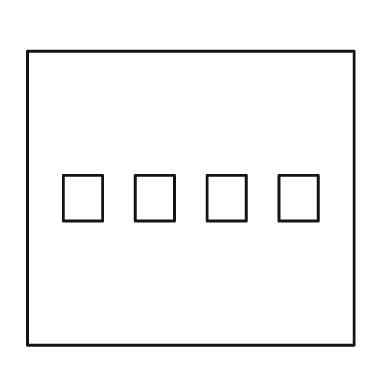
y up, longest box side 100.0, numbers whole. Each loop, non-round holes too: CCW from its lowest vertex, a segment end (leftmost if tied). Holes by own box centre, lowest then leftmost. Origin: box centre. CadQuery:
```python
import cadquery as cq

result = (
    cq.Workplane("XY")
    .moveTo(-50.0, -45.0)
    .lineTo(50.0, -45.0)
    .lineTo(50.0, 45.0)
    .lineTo(-50.0, 45.0)
    .close()
    .moveTo(-39.0, -7.0)
    .lineTo(-27.0, -7.0)
    .lineTo(-27.0, 7.0)
    .lineTo(-39.0, 7.0)
    .close()
    .moveTo(-17.0, -7.0)
    .lineTo(-5.0, -7.0)
    .lineTo(-5.0, 7.0)
    .lineTo(-17.0, 7.0)
    .close()
    .moveTo(5.0, -7.0)
    .lineTo(17.0, -7.0)
    .lineTo(17.0, 7.0)
    .lineTo(5.0, 7.0)
    .close()
    .moveTo(27.0, -7.0)
    .lineTo(39.0, -7.0)
    .lineTo(39.0, 7.0)
    .lineTo(27.0, 7.0)
    .close()
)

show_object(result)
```